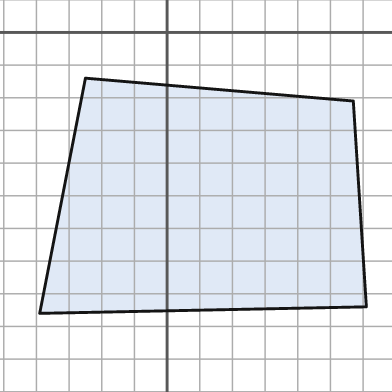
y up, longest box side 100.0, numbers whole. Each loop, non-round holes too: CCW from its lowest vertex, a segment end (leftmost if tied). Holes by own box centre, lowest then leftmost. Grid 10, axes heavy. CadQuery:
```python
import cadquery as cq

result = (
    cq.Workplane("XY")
    .moveTo(-39.0, -86.0)
    .lineTo(61.0, -84.0)
    .lineTo(57.0, -21.0)
    .lineTo(-25.0, -14.0)
    .close()
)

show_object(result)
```